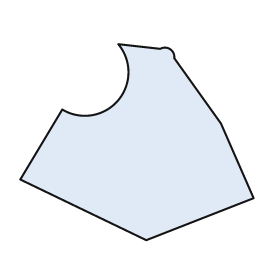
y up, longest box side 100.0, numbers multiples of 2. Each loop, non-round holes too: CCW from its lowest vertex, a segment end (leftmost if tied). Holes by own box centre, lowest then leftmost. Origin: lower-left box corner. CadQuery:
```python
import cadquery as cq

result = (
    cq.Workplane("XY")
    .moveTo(54.0, 0.0)
    .lineTo(100.0, 18.0)
    .lineTo(86.0, 50.0)
    .lineTo(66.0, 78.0)
    .threePointArc((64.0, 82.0), (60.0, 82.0))
    .lineTo(42.0, 84.0)
    .threePointArc((42.0, 60.0), (18.0, 56.0))
    .lineTo(0.0, 26.0)
    .close()
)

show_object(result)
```